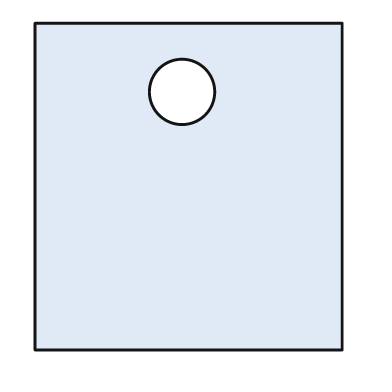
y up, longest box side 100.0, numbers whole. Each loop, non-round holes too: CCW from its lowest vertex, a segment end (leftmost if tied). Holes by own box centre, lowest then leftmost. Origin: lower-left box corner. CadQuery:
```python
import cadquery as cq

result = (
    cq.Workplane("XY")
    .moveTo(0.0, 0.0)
    .lineTo(94.0, 0.0)
    .lineTo(94.0, 100.0)
    .lineTo(0.0, 100.0)
    .close()
    .moveTo(45.0, 79.0)
    .circle(10.0)
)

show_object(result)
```